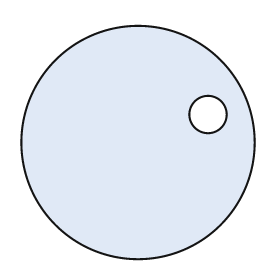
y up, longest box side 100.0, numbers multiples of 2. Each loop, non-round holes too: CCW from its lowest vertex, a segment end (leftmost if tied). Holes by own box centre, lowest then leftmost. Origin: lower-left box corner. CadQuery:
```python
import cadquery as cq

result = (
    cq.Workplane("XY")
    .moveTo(50.0, 50.0)
    .circle(50.0)
    .moveTo(80.0, 62.0)
    .circle(8.0)
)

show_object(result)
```